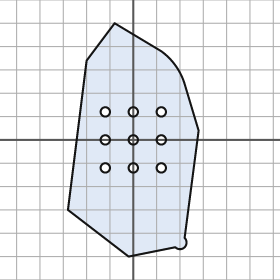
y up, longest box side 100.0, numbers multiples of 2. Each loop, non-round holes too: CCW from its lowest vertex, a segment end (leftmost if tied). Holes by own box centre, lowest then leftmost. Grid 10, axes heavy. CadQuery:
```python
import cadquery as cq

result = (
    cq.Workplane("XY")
    .moveTo(-2.0, -50.0)
    .lineTo(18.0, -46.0)
    .threePointArc((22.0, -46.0), (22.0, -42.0))
    .lineTo(28.0, 4.0)
    .lineTo(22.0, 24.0)
    .threePointArc((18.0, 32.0), (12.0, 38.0))
    .lineTo(-8.0, 50.0)
    .lineTo(-20.0, 34.0)
    .lineTo(-28.0, -30.0)
    .close()
    .moveTo(-12.0, -12.0)
    .circle(2.0)
    .moveTo(0.0, -12.0)
    .circle(2.0)
    .moveTo(12.0, -12.0)
    .circle(2.0)
    .moveTo(-12.0, 0.0)
    .circle(2.0)
    .moveTo(0.0, 0.0)
    .circle(2.0)
    .moveTo(12.0, 0.0)
    .circle(2.0)
    .moveTo(-12.0, 12.0)
    .circle(2.0)
    .moveTo(0.0, 12.0)
    .circle(2.0)
    .moveTo(12.0, 12.0)
    .circle(2.0)
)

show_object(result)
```